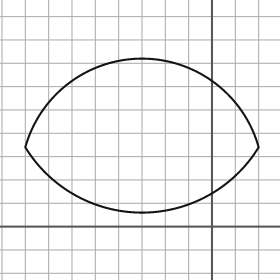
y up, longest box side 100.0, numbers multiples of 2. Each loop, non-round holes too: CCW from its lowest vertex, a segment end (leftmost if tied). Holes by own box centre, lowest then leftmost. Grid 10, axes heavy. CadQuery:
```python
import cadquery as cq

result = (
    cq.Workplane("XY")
    .moveTo(-80.0, 34.0)
    .threePointArc((-30.0, 6.0), (20.0, 34.0))
    .threePointArc((-30.0, 72.0), (-80.0, 34.0))
    .close()
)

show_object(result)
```